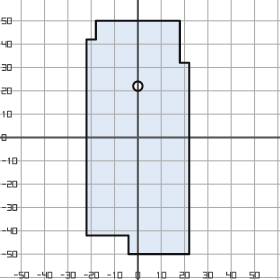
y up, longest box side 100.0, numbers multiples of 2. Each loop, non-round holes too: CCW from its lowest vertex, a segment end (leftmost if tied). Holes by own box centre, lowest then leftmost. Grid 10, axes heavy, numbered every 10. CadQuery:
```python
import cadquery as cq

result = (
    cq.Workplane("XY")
    .moveTo(-4.0, -50.0)
    .lineTo(22.0, -50.0)
    .lineTo(22.0, 32.0)
    .lineTo(18.0, 32.0)
    .lineTo(18.0, 50.0)
    .lineTo(-18.0, 50.0)
    .lineTo(-18.0, 42.0)
    .lineTo(-22.0, 42.0)
    .lineTo(-22.0, -42.0)
    .lineTo(-4.0, -42.0)
    .close()
    .moveTo(0.0, 22.0)
    .circle(2.0)
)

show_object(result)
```